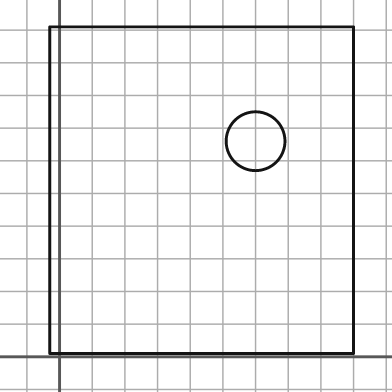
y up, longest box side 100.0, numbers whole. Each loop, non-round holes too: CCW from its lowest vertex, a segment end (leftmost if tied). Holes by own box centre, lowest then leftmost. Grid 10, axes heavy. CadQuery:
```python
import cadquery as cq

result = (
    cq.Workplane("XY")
    .moveTo(-3.0, 1.0)
    .lineTo(90.0, 1.0)
    .lineTo(90.0, 101.0)
    .lineTo(-3.0, 101.0)
    .close()
    .moveTo(60.0, 66.0)
    .circle(9.0)
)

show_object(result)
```